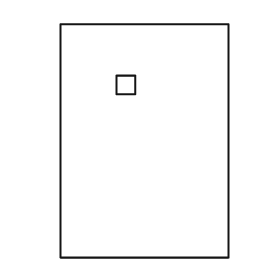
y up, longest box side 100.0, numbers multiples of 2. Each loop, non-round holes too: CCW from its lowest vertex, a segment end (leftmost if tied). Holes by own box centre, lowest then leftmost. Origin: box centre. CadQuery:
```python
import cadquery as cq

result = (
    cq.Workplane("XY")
    .moveTo(-36.0, -50.0)
    .lineTo(36.0, -50.0)
    .lineTo(36.0, 50.0)
    .lineTo(-36.0, 50.0)
    .close()
    .moveTo(-12.0, 20.0)
    .lineTo(-4.0, 20.0)
    .lineTo(-4.0, 28.0)
    .lineTo(-12.0, 28.0)
    .close()
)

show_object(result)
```